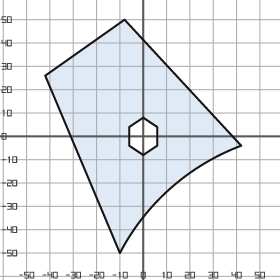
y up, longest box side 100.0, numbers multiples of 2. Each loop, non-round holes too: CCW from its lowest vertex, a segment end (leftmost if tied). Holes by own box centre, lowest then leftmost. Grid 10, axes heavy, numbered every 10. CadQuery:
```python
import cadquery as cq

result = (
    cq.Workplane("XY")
    .moveTo(-10.0, -50.0)
    .threePointArc((12.0, -22.0), (42.0, -4.0))
    .lineTo(-8.0, 50.0)
    .lineTo(-42.0, 26.0)
    .close()
    .moveTo(0.0, -8.0)
    .lineTo(6.0, -4.0)
    .lineTo(6.0, 4.0)
    .lineTo(0.0, 8.0)
    .lineTo(-6.0, 4.0)
    .lineTo(-6.0, -4.0)
    .close()
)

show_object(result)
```